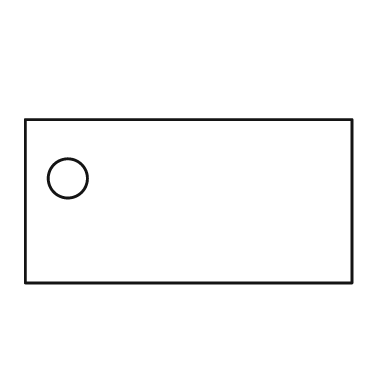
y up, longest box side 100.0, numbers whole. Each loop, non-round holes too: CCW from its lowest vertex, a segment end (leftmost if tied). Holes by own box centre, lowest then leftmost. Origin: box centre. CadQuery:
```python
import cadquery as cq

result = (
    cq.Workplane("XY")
    .moveTo(-50.0, -25.0)
    .lineTo(50.0, -25.0)
    .lineTo(50.0, 25.0)
    .lineTo(-50.0, 25.0)
    .close()
    .moveTo(-37.0, 7.0)
    .circle(6.0)
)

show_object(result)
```